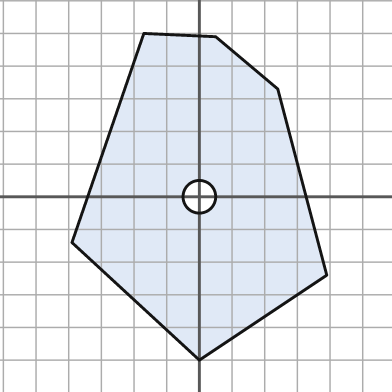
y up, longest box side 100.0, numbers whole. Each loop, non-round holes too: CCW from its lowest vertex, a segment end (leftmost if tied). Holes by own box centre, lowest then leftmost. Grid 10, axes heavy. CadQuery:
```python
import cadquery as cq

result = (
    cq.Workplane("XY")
    .moveTo(0.0, -50.0)
    .lineTo(39.0, -24.0)
    .lineTo(24.0, 33.0)
    .lineTo(5.0, 49.0)
    .lineTo(-17.0, 50.0)
    .lineTo(-39.0, -14.0)
    .close()
    .moveTo(0.0, 0.0)
    .circle(5.0)
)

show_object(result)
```